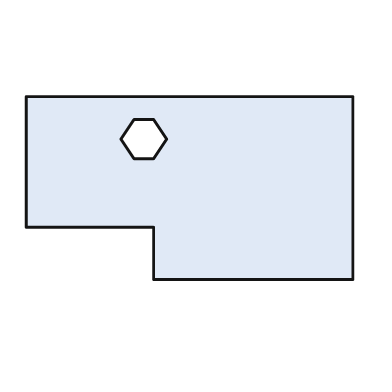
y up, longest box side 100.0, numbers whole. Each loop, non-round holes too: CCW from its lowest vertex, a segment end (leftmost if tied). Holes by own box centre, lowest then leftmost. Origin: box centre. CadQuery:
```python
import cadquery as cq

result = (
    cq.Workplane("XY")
    .moveTo(-11.0, -28.0)
    .lineTo(50.0, -28.0)
    .lineTo(50.0, 28.0)
    .lineTo(-50.0, 28.0)
    .lineTo(-50.0, -12.0)
    .lineTo(-11.0, -12.0)
    .close()
    .moveTo(-17.0, 9.0)
    .lineTo(-11.0, 9.0)
    .lineTo(-7.0, 15.0)
    .lineTo(-11.0, 21.0)
    .lineTo(-17.0, 21.0)
    .lineTo(-21.0, 15.0)
    .close()
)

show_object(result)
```